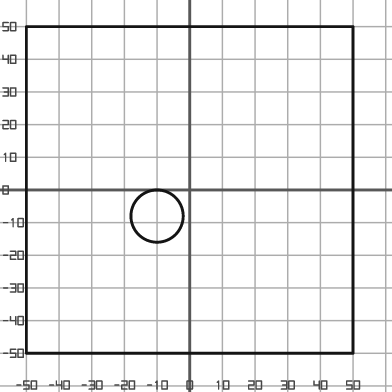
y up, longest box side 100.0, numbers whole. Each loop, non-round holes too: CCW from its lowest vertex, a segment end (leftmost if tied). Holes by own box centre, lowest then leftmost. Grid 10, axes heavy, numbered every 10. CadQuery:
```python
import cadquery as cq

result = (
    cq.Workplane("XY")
    .moveTo(-50.0, -50.0)
    .lineTo(50.0, -50.0)
    .lineTo(50.0, 50.0)
    .lineTo(-50.0, 50.0)
    .close()
    .moveTo(-10.0, -8.0)
    .circle(8.0)
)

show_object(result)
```